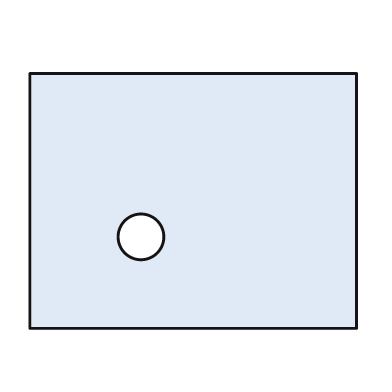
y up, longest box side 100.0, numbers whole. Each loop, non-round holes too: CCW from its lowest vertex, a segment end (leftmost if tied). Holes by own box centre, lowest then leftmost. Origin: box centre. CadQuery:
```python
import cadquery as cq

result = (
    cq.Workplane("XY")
    .moveTo(-50.0, -39.0)
    .lineTo(50.0, -39.0)
    .lineTo(50.0, 39.0)
    .lineTo(-50.0, 39.0)
    .close()
    .moveTo(-16.0, -11.0)
    .circle(7.0)
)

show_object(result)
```